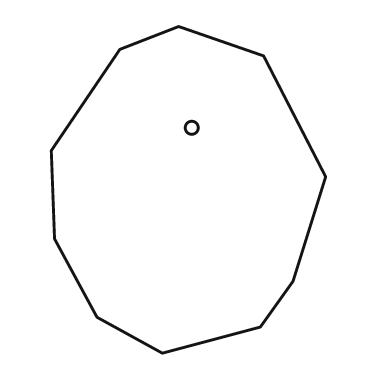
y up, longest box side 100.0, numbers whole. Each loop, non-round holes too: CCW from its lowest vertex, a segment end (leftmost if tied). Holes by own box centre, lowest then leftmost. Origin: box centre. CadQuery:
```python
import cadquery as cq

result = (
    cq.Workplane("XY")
    .moveTo(-8.0, -50.0)
    .lineTo(22.0, -42.0)
    .lineTo(32.0, -28.0)
    .lineTo(42.0, 4.0)
    .lineTo(23.0, 41.0)
    .lineTo(-3.0, 50.0)
    .lineTo(-21.0, 43.0)
    .lineTo(-42.0, 12.0)
    .lineTo(-41.0, -15.0)
    .lineTo(-28.0, -39.0)
    .close()
    .moveTo(1.0, 19.0)
    .circle(2.0)
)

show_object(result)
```